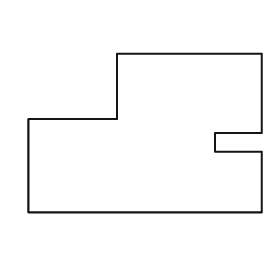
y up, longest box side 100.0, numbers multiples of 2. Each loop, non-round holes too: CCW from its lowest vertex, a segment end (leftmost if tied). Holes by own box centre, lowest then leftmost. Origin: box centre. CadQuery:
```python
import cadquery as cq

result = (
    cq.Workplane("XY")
    .moveTo(-50.0, -34.0)
    .lineTo(50.0, -34.0)
    .lineTo(50.0, -8.0)
    .lineTo(30.0, -8.0)
    .lineTo(30.0, 0.0)
    .lineTo(50.0, 0.0)
    .lineTo(50.0, 34.0)
    .lineTo(-12.0, 34.0)
    .lineTo(-12.0, 6.0)
    .lineTo(-50.0, 6.0)
    .close()
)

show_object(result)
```